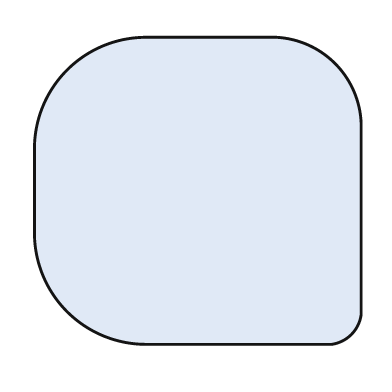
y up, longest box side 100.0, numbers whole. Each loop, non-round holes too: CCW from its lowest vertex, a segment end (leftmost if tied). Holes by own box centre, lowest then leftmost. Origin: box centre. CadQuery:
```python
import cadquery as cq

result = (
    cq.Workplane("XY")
    .moveTo(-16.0, -47.0)
    .lineTo(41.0, -47.0)
    .threePointArc((47.0, -44.0), (50.0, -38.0))
    .lineTo(50.0, 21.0)
    .threePointArc((42.0, 39.0), (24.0, 47.0))
    .lineTo(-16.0, 47.0)
    .threePointArc((-40.0, 37.0), (-50.0, 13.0))
    .lineTo(-50.0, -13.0)
    .threePointArc((-40.0, -37.0), (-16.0, -47.0))
    .close()
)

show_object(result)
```